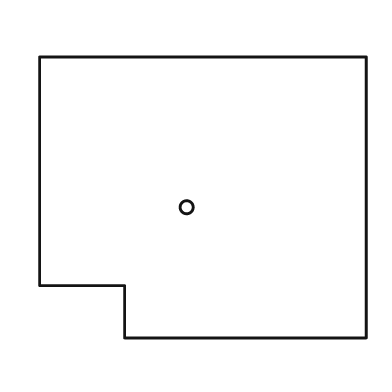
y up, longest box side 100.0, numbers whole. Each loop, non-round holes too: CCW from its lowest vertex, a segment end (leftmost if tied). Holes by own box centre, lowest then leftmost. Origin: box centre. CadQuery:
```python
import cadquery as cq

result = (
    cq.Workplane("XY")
    .moveTo(-24.0, -43.0)
    .lineTo(50.0, -43.0)
    .lineTo(50.0, 43.0)
    .lineTo(-50.0, 43.0)
    .lineTo(-50.0, -27.0)
    .lineTo(-24.0, -27.0)
    .close()
    .moveTo(-5.0, -3.0)
    .circle(2.0)
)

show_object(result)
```